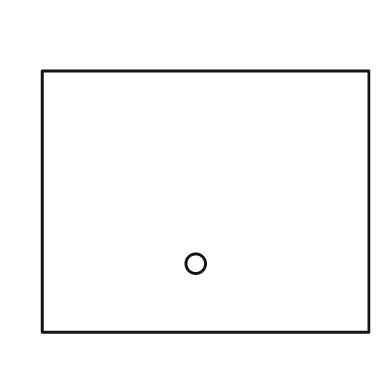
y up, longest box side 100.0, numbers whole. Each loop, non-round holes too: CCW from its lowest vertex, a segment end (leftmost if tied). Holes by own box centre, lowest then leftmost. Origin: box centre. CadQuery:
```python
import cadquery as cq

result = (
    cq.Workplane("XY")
    .moveTo(-50.0, -40.0)
    .lineTo(50.0, -40.0)
    .lineTo(50.0, 40.0)
    .lineTo(-50.0, 40.0)
    .close()
    .moveTo(-3.0, -19.0)
    .circle(3.0)
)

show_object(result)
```